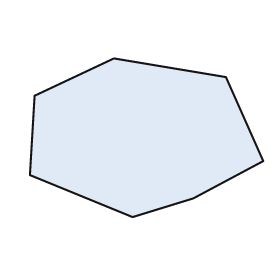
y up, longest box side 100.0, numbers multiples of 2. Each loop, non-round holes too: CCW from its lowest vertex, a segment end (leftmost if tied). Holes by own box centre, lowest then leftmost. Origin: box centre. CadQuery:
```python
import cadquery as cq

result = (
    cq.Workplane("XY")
    .moveTo(-6.0, -34.0)
    .lineTo(20.0, -26.0)
    .lineTo(50.0, -10.0)
    .lineTo(34.0, 26.0)
    .lineTo(-14.0, 34.0)
    .lineTo(-48.0, 18.0)
    .lineTo(-50.0, -16.0)
    .close()
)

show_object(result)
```